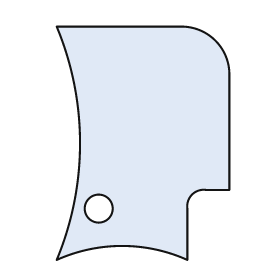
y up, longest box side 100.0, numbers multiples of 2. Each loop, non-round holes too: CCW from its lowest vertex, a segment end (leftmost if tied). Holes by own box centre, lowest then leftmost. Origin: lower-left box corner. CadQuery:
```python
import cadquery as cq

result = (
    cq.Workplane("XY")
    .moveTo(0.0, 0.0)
    .threePointArc((28.0, 6.0), (56.0, 0.0))
    .lineTo(56.0, 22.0)
    .threePointArc((58.0, 28.0), (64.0, 30.0))
    .lineTo(74.0, 30.0)
    .lineTo(74.0, 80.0)
    .threePointArc((68.0, 94.0), (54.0, 100.0))
    .lineTo(0.0, 100.0)
    .threePointArc((10.0, 50.0), (0.0, 0.0))
    .close()
    .moveTo(18.0, 22.0)
    .circle(6.0)
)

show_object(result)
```